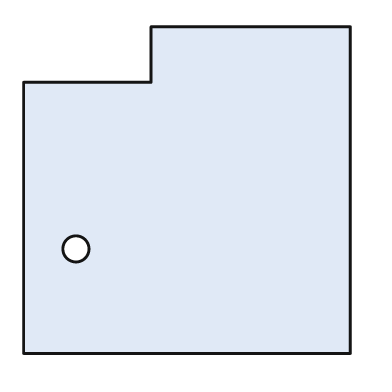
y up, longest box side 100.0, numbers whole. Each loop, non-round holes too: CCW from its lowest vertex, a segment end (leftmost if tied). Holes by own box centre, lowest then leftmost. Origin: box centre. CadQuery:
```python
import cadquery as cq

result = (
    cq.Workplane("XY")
    .moveTo(-50.0, -50.0)
    .lineTo(50.0, -50.0)
    .lineTo(50.0, 50.0)
    .lineTo(-11.0, 50.0)
    .lineTo(-11.0, 33.0)
    .lineTo(-50.0, 33.0)
    .close()
    .moveTo(-34.0, -18.0)
    .circle(4.0)
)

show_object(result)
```